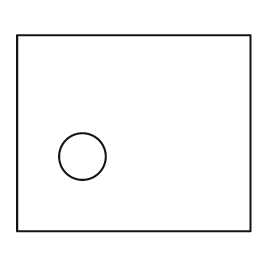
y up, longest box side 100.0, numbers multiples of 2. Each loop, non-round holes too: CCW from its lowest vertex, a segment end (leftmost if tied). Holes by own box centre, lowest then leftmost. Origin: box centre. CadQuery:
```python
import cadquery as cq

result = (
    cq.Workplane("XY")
    .moveTo(-50.0, -42.0)
    .lineTo(50.0, -42.0)
    .lineTo(50.0, 42.0)
    .lineTo(-50.0, 42.0)
    .close()
    .moveTo(-22.0, -10.0)
    .circle(10.0)
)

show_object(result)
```